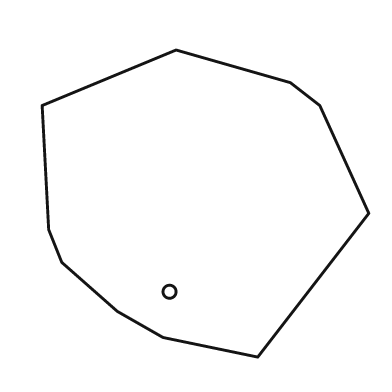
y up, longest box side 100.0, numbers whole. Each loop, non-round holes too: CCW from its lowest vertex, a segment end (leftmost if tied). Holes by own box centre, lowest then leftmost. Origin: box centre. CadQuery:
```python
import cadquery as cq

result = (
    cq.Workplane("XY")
    .moveTo(16.0, -47.0)
    .lineTo(50.0, -3.0)
    .lineTo(35.0, 30.0)
    .lineTo(26.0, 37.0)
    .lineTo(-9.0, 47.0)
    .lineTo(-50.0, 30.0)
    .lineTo(-48.0, -8.0)
    .lineTo(-44.0, -18.0)
    .lineTo(-27.0, -33.0)
    .lineTo(-13.0, -41.0)
    .close()
    .moveTo(-11.0, -27.0)
    .circle(2.0)
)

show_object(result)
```